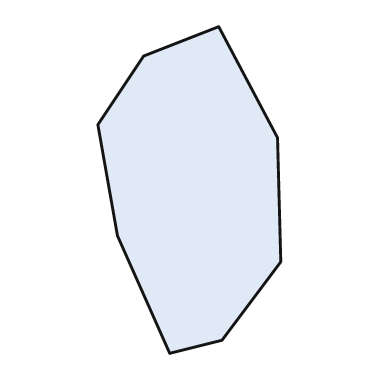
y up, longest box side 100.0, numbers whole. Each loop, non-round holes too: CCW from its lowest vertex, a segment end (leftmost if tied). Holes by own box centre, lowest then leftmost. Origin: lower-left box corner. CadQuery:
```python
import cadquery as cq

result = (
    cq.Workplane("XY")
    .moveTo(22.0, 0.0)
    .lineTo(38.0, 4.0)
    .lineTo(56.0, 28.0)
    .lineTo(55.0, 66.0)
    .lineTo(37.0, 100.0)
    .lineTo(14.0, 91.0)
    .lineTo(0.0, 70.0)
    .lineTo(6.0, 36.0)
    .close()
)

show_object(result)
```